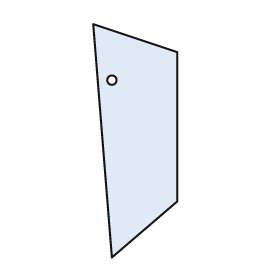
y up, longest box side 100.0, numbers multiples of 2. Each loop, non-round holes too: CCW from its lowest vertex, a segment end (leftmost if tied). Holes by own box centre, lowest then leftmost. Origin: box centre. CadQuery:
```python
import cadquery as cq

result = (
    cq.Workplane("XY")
    .moveTo(-10.0, -50.0)
    .lineTo(18.0, -26.0)
    .lineTo(18.0, 38.0)
    .lineTo(-18.0, 50.0)
    .close()
    .moveTo(-10.0, 26.0)
    .circle(2.0)
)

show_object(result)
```